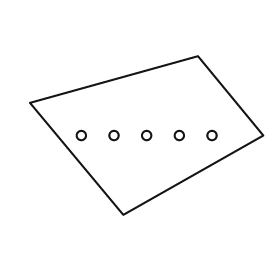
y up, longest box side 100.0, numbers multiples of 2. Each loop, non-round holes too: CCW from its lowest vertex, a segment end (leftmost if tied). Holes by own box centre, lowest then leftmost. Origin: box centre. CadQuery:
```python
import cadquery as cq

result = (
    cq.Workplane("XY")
    .moveTo(-10.0, -34.0)
    .lineTo(50.0, 0.0)
    .lineTo(22.0, 34.0)
    .lineTo(-50.0, 14.0)
    .close()
    .moveTo(-28.0, 0.0)
    .circle(2.0)
    .moveTo(-14.0, 0.0)
    .circle(2.0)
    .moveTo(0.0, 0.0)
    .circle(2.0)
    .moveTo(14.0, 0.0)
    .circle(2.0)
    .moveTo(28.0, 0.0)
    .circle(2.0)
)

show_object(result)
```